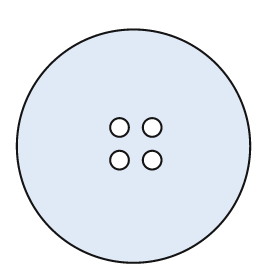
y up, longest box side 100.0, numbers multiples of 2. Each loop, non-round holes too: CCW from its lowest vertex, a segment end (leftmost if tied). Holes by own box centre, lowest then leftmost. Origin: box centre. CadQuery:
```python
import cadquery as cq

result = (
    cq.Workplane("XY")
    .moveTo(0.0, 0.0)
    .circle(50.0)
    .moveTo(-6.0, -6.0)
    .circle(4.0)
    .moveTo(8.0, -6.0)
    .circle(4.0)
    .moveTo(-6.0, 8.0)
    .circle(4.0)
    .moveTo(8.0, 8.0)
    .circle(4.0)
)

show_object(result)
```